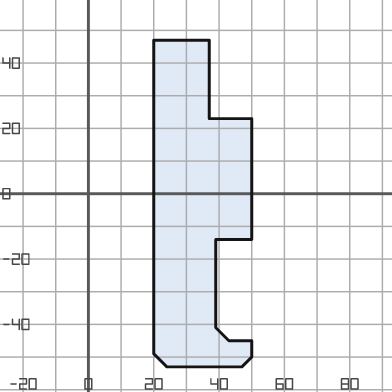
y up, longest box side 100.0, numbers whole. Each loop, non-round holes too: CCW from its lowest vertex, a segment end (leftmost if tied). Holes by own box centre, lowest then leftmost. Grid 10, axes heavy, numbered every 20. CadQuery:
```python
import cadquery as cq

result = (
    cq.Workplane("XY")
    .moveTo(24.0, -53.0)
    .lineTo(47.0, -53.0)
    .lineTo(50.0, -50.0)
    .lineTo(50.0, -45.0)
    .lineTo(43.0, -45.0)
    .lineTo(39.0, -41.0)
    .lineTo(39.0, -14.0)
    .lineTo(50.0, -14.0)
    .lineTo(50.0, 23.0)
    .lineTo(37.0, 23.0)
    .lineTo(37.0, 47.0)
    .lineTo(20.0, 47.0)
    .lineTo(20.0, -49.0)
    .close()
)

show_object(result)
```